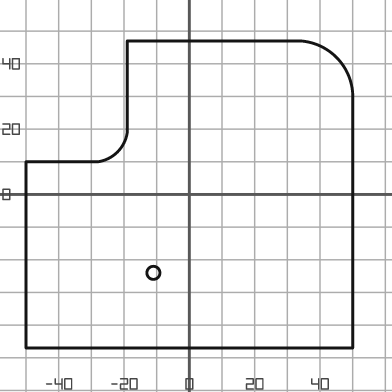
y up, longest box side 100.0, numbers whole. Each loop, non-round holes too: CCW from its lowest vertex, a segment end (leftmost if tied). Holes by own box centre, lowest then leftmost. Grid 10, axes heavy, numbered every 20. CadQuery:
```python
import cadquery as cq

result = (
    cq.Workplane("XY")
    .moveTo(-50.0, -47.0)
    .lineTo(50.0, -47.0)
    .lineTo(50.0, 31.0)
    .threePointArc((45.0, 42.0), (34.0, 47.0))
    .lineTo(-19.0, 47.0)
    .lineTo(-19.0, 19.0)
    .threePointArc((-22.0, 13.0), (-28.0, 10.0))
    .lineTo(-50.0, 10.0)
    .close()
    .moveTo(-11.0, -24.0)
    .circle(2.0)
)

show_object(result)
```